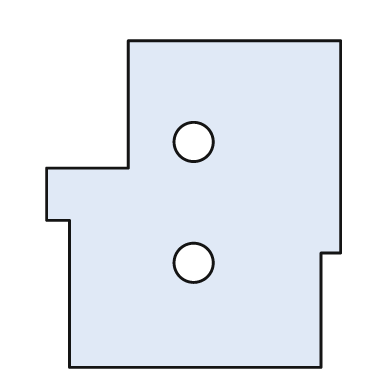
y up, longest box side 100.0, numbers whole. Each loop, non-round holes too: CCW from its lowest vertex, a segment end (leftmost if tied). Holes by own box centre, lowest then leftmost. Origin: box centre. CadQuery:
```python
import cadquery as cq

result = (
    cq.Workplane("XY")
    .moveTo(-38.0, -50.0)
    .lineTo(39.0, -50.0)
    .lineTo(39.0, -15.0)
    .lineTo(45.0, -15.0)
    .lineTo(45.0, 50.0)
    .lineTo(-20.0, 50.0)
    .lineTo(-20.0, 11.0)
    .lineTo(-45.0, 11.0)
    .lineTo(-45.0, -5.0)
    .lineTo(-38.0, -5.0)
    .close()
    .moveTo(0.0, -18.0)
    .circle(6.0)
    .moveTo(0.0, 19.0)
    .circle(6.0)
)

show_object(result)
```